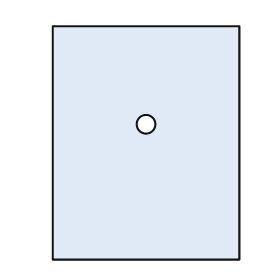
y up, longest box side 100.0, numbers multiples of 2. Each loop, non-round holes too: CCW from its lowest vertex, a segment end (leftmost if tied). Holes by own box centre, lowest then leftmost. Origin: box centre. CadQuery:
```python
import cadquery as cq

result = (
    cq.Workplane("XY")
    .moveTo(-40.0, -50.0)
    .lineTo(40.0, -50.0)
    .lineTo(40.0, 50.0)
    .lineTo(-40.0, 50.0)
    .close()
    .moveTo(0.0, 8.0)
    .circle(4.0)
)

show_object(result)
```